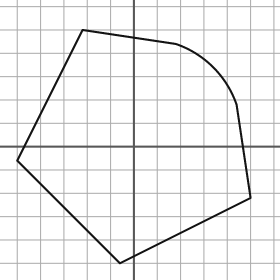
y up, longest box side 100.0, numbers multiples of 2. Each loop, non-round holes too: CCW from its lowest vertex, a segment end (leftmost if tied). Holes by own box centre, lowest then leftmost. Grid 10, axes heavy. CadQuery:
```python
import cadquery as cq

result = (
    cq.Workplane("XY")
    .moveTo(-6.0, -50.0)
    .lineTo(50.0, -22.0)
    .lineTo(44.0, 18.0)
    .threePointArc((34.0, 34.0), (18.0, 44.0))
    .lineTo(-22.0, 50.0)
    .lineTo(-50.0, -6.0)
    .close()
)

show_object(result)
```